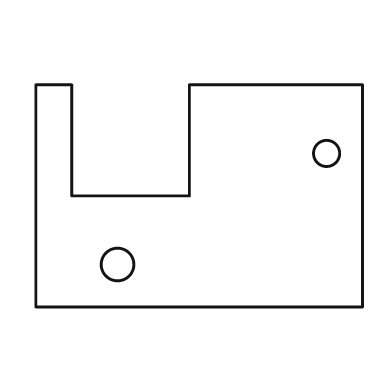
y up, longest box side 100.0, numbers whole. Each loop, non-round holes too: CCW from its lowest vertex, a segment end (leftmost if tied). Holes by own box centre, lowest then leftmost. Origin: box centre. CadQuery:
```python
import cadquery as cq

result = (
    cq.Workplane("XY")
    .moveTo(-50.0, -34.0)
    .lineTo(50.0, -34.0)
    .lineTo(50.0, 34.0)
    .lineTo(-3.0, 34.0)
    .lineTo(-3.0, 0.0)
    .lineTo(-39.0, 0.0)
    .lineTo(-39.0, 34.0)
    .lineTo(-50.0, 34.0)
    .close()
    .moveTo(-25.0, -21.0)
    .circle(5.0)
    .moveTo(39.0, 13.0)
    .circle(4.0)
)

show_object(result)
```